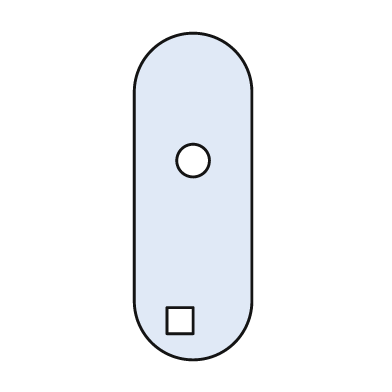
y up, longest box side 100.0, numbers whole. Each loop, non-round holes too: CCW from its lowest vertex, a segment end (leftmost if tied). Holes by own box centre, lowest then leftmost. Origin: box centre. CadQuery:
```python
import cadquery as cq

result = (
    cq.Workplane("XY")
    .moveTo(-18.0, -32.0)
    .threePointArc((0.0, -50.0), (18.0, -32.0))
    .lineTo(18.0, 32.0)
    .threePointArc((0.0, 50.0), (-18.0, 32.0))
    .close()
    .moveTo(-8.0, -42.0)
    .lineTo(0.0, -42.0)
    .lineTo(0.0, -34.0)
    .lineTo(-8.0, -34.0)
    .close()
    .moveTo(0.0, 11.0)
    .circle(5.0)
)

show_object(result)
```